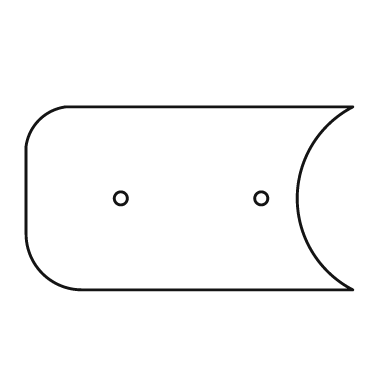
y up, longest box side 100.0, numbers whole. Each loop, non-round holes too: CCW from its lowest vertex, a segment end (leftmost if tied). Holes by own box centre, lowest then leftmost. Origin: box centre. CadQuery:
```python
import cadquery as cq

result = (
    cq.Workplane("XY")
    .moveTo(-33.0, -28.0)
    .lineTo(50.0, -28.0)
    .threePointArc((33.0, 0.0), (50.0, 28.0))
    .lineTo(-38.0, 28.0)
    .threePointArc((-46.0, 24.0), (-50.0, 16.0))
    .lineTo(-50.0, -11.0)
    .threePointArc((-45.0, -23.0), (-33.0, -28.0))
    .close()
    .moveTo(-21.0, 0.0)
    .circle(2.0)
    .moveTo(22.0, 0.0)
    .circle(2.0)
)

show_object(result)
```